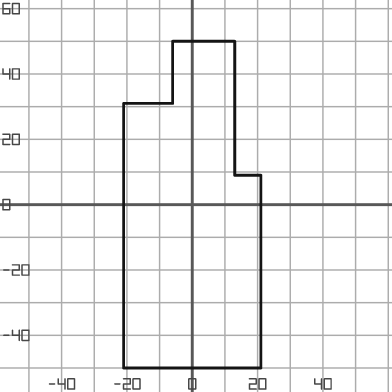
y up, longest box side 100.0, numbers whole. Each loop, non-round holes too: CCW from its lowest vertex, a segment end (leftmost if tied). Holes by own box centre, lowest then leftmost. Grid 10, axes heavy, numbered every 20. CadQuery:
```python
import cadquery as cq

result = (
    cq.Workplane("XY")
    .moveTo(-21.0, -50.0)
    .lineTo(21.0, -50.0)
    .lineTo(21.0, 9.0)
    .lineTo(13.0, 9.0)
    .lineTo(13.0, 50.0)
    .lineTo(-6.0, 50.0)
    .lineTo(-6.0, 31.0)
    .lineTo(-21.0, 31.0)
    .close()
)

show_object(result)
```